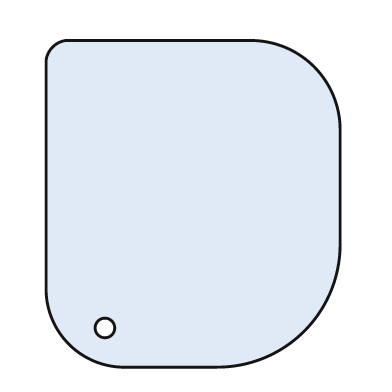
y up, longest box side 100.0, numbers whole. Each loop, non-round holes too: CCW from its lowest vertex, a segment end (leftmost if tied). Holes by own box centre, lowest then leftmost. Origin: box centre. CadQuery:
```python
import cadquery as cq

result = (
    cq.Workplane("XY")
    .moveTo(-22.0, -50.0)
    .lineTo(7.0, -50.0)
    .threePointArc((34.0, -39.0), (45.0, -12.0))
    .lineTo(45.0, 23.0)
    .threePointArc((37.0, 42.0), (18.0, 50.0))
    .lineTo(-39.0, 50.0)
    .threePointArc((-43.0, 48.0), (-45.0, 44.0))
    .lineTo(-45.0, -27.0)
    .threePointArc((-38.0, -43.0), (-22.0, -50.0))
    .close()
    .moveTo(-27.0, -38.0)
    .circle(3.0)
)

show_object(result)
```